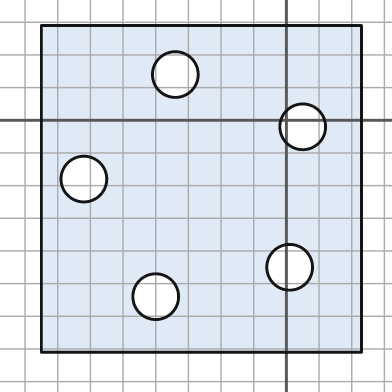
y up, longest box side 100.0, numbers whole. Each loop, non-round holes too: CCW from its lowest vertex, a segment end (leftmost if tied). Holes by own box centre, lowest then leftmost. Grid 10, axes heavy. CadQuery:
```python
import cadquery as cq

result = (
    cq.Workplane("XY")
    .moveTo(-75.0, -71.0)
    .lineTo(23.0, -71.0)
    .lineTo(23.0, 29.0)
    .lineTo(-75.0, 29.0)
    .close()
    .moveTo(-40.0, -54.0)
    .circle(7.0)
    .moveTo(1.0, -45.0)
    .circle(7.0)
    .moveTo(-62.0, -18.0)
    .circle(7.0)
    .moveTo(5.0, -2.0)
    .circle(7.0)
    .moveTo(-34.0, 14.0)
    .circle(7.0)
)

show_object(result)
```